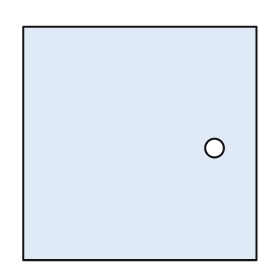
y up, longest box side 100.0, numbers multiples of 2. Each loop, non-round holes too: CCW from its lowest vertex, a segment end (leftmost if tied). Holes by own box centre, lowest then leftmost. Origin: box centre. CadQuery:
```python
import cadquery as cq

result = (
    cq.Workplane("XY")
    .moveTo(-50.0, -50.0)
    .lineTo(50.0, -50.0)
    .lineTo(50.0, 50.0)
    .lineTo(-50.0, 50.0)
    .close()
    .moveTo(32.0, -2.0)
    .circle(4.0)
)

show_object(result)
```